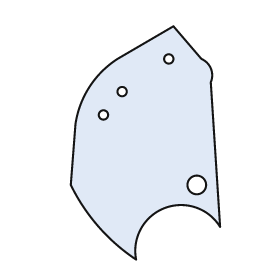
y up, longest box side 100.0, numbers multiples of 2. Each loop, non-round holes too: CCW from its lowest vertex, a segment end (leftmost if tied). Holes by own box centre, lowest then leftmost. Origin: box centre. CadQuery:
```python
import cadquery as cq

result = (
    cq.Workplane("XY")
    .moveTo(-4.0, -50.0)
    .threePointArc((8.0, -28.0), (32.0, -36.0))
    .lineTo(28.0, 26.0)
    .threePointArc((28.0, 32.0), (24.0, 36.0))
    .lineTo(12.0, 50.0)
    .lineTo(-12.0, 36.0)
    .threePointArc((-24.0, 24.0), (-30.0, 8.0))
    .lineTo(-32.0, -18.0)
    .threePointArc((-20.0, -36.0), (-4.0, -50.0))
    .close()
    .moveTo(22.0, -18.0)
    .circle(4.0)
    .moveTo(-18.0, 12.0)
    .circle(2.0)
    .moveTo(-10.0, 22.0)
    .circle(2.0)
    .moveTo(10.0, 36.0)
    .circle(2.0)
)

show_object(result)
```